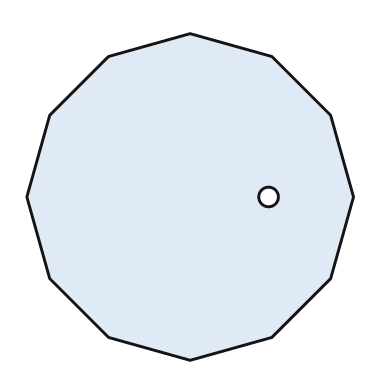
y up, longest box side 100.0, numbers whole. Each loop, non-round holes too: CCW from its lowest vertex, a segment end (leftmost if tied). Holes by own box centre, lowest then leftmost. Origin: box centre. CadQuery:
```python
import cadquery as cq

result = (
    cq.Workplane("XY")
    .moveTo(0.0, -50.0)
    .lineTo(25.0, -43.0)
    .lineTo(43.0, -25.0)
    .lineTo(50.0, 0.0)
    .lineTo(43.0, 25.0)
    .lineTo(25.0, 43.0)
    .lineTo(0.0, 50.0)
    .lineTo(-25.0, 43.0)
    .lineTo(-43.0, 25.0)
    .lineTo(-50.0, 0.0)
    .lineTo(-43.0, -25.0)
    .lineTo(-25.0, -43.0)
    .close()
    .moveTo(24.0, 0.0)
    .circle(3.0)
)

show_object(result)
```